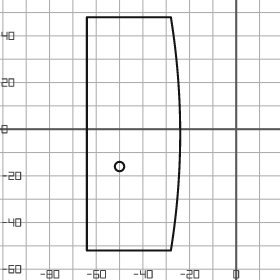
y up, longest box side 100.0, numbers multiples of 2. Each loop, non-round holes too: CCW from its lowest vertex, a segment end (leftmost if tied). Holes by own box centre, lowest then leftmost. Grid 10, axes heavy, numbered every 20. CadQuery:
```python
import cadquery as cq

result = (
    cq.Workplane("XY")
    .moveTo(-64.0, -52.0)
    .lineTo(-28.0, -52.0)
    .threePointArc((-24.0, -2.0), (-28.0, 48.0))
    .lineTo(-64.0, 48.0)
    .close()
    .moveTo(-50.0, -16.0)
    .circle(2.0)
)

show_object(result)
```